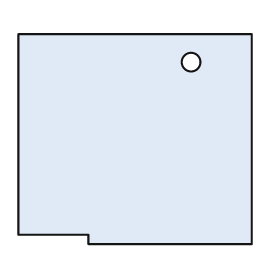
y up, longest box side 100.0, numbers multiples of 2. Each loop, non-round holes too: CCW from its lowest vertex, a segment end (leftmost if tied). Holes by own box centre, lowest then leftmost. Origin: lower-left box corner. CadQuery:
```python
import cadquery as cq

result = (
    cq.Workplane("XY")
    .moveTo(30.0, 0.0)
    .lineTo(100.0, 0.0)
    .lineTo(100.0, 90.0)
    .lineTo(0.0, 90.0)
    .lineTo(0.0, 4.0)
    .lineTo(30.0, 4.0)
    .close()
    .moveTo(74.0, 78.0)
    .circle(4.0)
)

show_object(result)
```